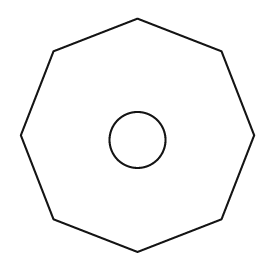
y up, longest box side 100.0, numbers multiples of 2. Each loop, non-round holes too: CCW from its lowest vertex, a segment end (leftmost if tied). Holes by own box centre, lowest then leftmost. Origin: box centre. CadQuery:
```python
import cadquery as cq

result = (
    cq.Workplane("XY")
    .moveTo(0.0, -50.0)
    .lineTo(36.0, -36.0)
    .lineTo(50.0, 0.0)
    .lineTo(36.0, 36.0)
    .lineTo(0.0, 50.0)
    .lineTo(-36.0, 36.0)
    .lineTo(-50.0, 0.0)
    .lineTo(-36.0, -36.0)
    .close()
    .moveTo(0.0, -2.0)
    .circle(12.0)
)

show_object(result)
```